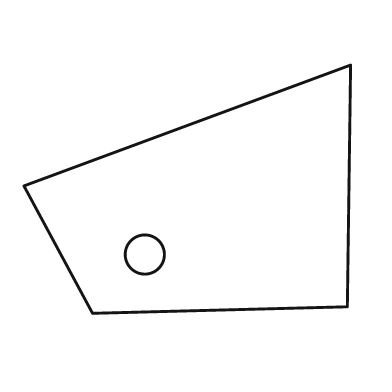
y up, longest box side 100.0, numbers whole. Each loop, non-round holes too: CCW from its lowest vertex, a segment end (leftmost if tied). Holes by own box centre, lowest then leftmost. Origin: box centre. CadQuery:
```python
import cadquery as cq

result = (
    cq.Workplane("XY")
    .moveTo(-29.0, -38.0)
    .lineTo(49.0, -36.0)
    .lineTo(50.0, 38.0)
    .lineTo(-50.0, 1.0)
    .close()
    .moveTo(-13.0, -20.0)
    .circle(6.0)
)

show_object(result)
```